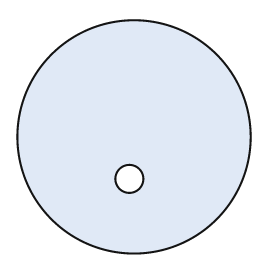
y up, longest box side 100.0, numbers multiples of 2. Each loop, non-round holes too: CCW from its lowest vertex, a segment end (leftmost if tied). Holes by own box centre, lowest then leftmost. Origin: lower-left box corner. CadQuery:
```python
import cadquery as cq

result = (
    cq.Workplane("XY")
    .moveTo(50.0, 50.0)
    .circle(50.0)
    .moveTo(48.0, 32.0)
    .circle(6.0)
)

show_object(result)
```